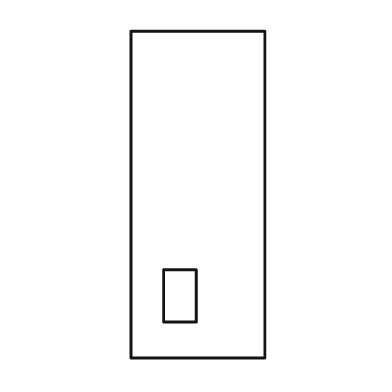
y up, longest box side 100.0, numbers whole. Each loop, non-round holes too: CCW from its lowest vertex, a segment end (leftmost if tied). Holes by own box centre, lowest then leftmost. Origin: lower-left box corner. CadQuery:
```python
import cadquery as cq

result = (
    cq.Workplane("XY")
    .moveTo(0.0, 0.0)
    .lineTo(41.0, 0.0)
    .lineTo(41.0, 100.0)
    .lineTo(0.0, 100.0)
    .close()
    .moveTo(10.0, 11.0)
    .lineTo(20.0, 11.0)
    .lineTo(20.0, 27.0)
    .lineTo(10.0, 27.0)
    .close()
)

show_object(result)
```